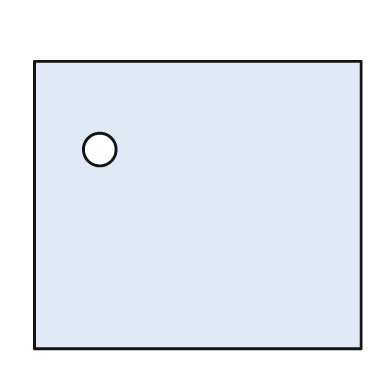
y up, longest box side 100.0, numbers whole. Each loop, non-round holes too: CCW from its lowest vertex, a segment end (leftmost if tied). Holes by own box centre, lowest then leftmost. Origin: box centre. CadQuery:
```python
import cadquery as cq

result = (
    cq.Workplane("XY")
    .moveTo(-50.0, -44.0)
    .lineTo(50.0, -44.0)
    .lineTo(50.0, 44.0)
    .lineTo(-50.0, 44.0)
    .close()
    .moveTo(-30.0, 17.0)
    .circle(5.0)
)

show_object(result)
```